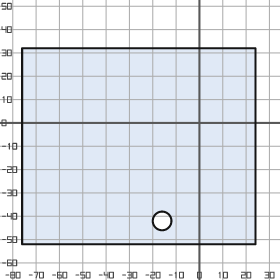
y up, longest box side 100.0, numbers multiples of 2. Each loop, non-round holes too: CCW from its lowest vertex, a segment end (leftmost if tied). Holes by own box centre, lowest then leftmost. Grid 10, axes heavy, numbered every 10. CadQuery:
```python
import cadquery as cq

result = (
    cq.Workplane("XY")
    .moveTo(-76.0, -52.0)
    .lineTo(24.0, -52.0)
    .lineTo(24.0, 32.0)
    .lineTo(-76.0, 32.0)
    .close()
    .moveTo(-16.0, -42.0)
    .circle(4.0)
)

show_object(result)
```